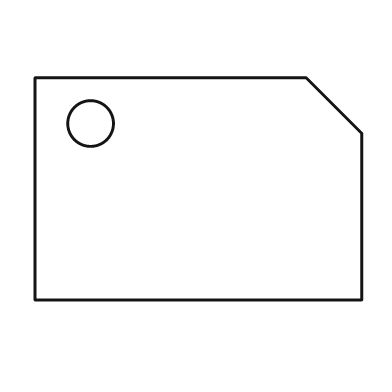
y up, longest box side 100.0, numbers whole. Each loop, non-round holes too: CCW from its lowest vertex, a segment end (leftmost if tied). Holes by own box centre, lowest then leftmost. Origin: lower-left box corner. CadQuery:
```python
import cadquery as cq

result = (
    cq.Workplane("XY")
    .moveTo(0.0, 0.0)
    .lineTo(100.0, 0.0)
    .lineTo(100.0, 51.0)
    .lineTo(83.0, 68.0)
    .lineTo(0.0, 68.0)
    .close()
    .moveTo(17.0, 54.0)
    .circle(7.0)
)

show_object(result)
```